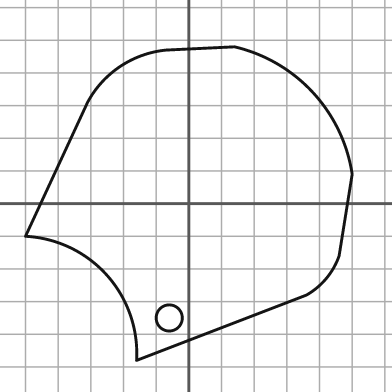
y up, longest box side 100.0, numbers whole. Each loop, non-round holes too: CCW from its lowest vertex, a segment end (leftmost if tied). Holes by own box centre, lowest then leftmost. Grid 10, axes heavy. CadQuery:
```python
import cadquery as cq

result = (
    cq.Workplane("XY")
    .moveTo(-16.0, -48.0)
    .lineTo(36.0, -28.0)
    .threePointArc((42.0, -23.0), (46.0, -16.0))
    .lineTo(50.0, 9.0)
    .threePointArc((38.0, 34.0), (14.0, 48.0))
    .lineTo(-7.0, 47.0)
    .threePointArc((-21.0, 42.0), (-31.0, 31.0))
    .lineTo(-50.0, -10.0)
    .threePointArc((-25.0, -22.0), (-16.0, -48.0))
    .close()
    .moveTo(-6.0, -35.0)
    .circle(4.0)
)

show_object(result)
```